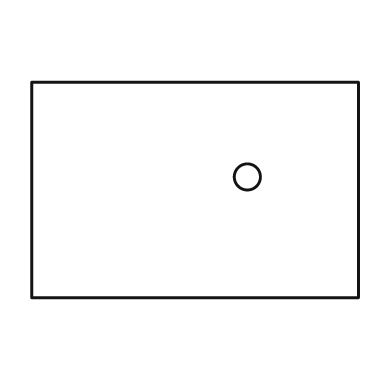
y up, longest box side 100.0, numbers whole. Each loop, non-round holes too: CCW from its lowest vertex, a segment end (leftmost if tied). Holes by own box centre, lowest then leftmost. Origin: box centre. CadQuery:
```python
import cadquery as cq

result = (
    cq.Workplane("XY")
    .moveTo(-50.0, -33.0)
    .lineTo(50.0, -33.0)
    .lineTo(50.0, 33.0)
    .lineTo(-50.0, 33.0)
    .close()
    .moveTo(16.0, 4.0)
    .circle(4.0)
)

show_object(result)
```